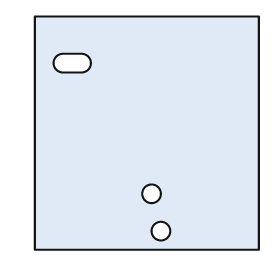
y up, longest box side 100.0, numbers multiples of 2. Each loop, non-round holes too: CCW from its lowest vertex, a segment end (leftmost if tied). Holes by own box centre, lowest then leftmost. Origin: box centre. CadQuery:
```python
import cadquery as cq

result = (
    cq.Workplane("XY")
    .moveTo(-48.0, -50.0)
    .lineTo(48.0, -50.0)
    .lineTo(48.0, 50.0)
    .lineTo(-48.0, 50.0)
    .close()
    .moveTo(6.0, -42.0)
    .circle(4.0)
    .moveTo(2.0, -26.0)
    .circle(4.0)
    .moveTo(-36.0, 26.0)
    .lineTo(-28.0, 26.0)
    .threePointArc((-24.0, 30.0), (-28.0, 34.0))
    .lineTo(-36.0, 34.0)
    .threePointArc((-40.0, 30.0), (-36.0, 26.0))
    .close()
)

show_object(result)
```